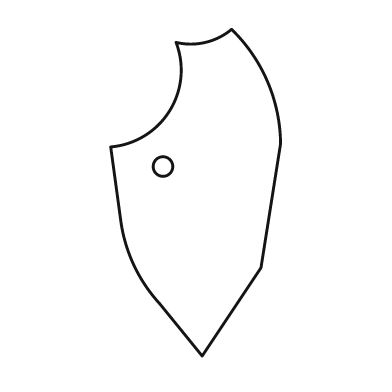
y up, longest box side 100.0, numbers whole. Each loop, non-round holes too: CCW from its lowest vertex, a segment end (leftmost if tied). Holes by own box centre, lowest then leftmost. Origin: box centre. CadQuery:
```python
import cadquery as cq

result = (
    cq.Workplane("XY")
    .moveTo(2.0, -50.0)
    .lineTo(20.0, -23.0)
    .lineTo(26.0, 15.0)
    .threePointArc((22.0, 34.0), (11.0, 50.0))
    .threePointArc((3.0, 46.0), (-6.0, 46.0))
    .threePointArc((-8.0, 25.0), (-26.0, 14.0))
    .lineTo(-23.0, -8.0)
    .threePointArc((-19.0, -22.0), (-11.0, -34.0))
    .close()
    .moveTo(-10.0, 8.0)
    .circle(3.0)
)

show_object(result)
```